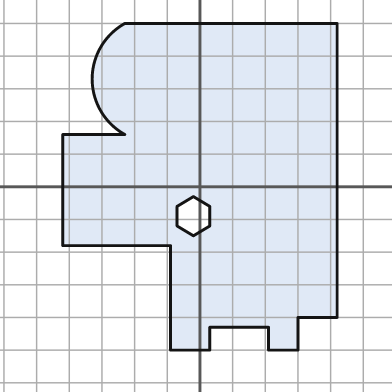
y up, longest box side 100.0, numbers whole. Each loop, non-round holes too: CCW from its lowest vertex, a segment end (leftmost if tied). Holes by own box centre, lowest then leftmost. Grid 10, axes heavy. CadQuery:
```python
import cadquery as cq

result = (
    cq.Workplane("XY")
    .moveTo(-9.0, -50.0)
    .lineTo(3.0, -50.0)
    .lineTo(3.0, -43.0)
    .lineTo(21.0, -43.0)
    .lineTo(21.0, -50.0)
    .lineTo(30.0, -50.0)
    .lineTo(30.0, -40.0)
    .lineTo(42.0, -40.0)
    .lineTo(42.0, 50.0)
    .lineTo(-23.0, 50.0)
    .threePointArc((-33.0, 33.0), (-23.0, 16.0))
    .lineTo(-42.0, 16.0)
    .lineTo(-42.0, -18.0)
    .lineTo(-9.0, -18.0)
    .close()
    .moveTo(-2.0, -15.0)
    .lineTo(3.0, -12.0)
    .lineTo(3.0, -6.0)
    .lineTo(-2.0, -3.0)
    .lineTo(-7.0, -6.0)
    .lineTo(-7.0, -12.0)
    .close()
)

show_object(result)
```